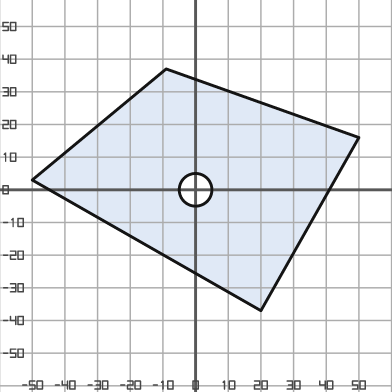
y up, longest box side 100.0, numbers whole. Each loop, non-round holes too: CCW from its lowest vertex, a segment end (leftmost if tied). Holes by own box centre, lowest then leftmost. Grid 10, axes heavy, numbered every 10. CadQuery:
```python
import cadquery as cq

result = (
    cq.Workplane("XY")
    .moveTo(20.0, -37.0)
    .lineTo(50.0, 16.0)
    .lineTo(-9.0, 37.0)
    .lineTo(-50.0, 3.0)
    .close()
    .moveTo(0.0, 0.0)
    .circle(5.0)
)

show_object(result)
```